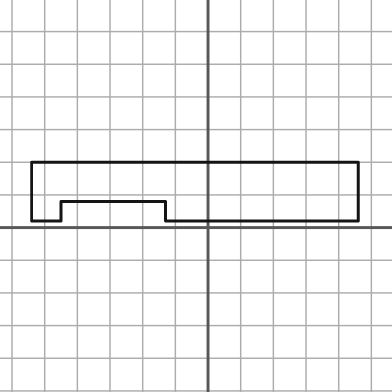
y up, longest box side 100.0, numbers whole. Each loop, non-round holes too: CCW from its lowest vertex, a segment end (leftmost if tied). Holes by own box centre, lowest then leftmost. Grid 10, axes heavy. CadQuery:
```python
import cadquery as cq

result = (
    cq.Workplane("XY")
    .moveTo(-54.0, 2.0)
    .lineTo(-45.0, 2.0)
    .lineTo(-45.0, 8.0)
    .lineTo(-13.0, 8.0)
    .lineTo(-13.0, 2.0)
    .lineTo(46.0, 2.0)
    .lineTo(46.0, 20.0)
    .lineTo(-54.0, 20.0)
    .close()
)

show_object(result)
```